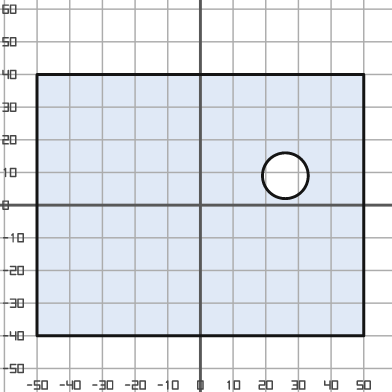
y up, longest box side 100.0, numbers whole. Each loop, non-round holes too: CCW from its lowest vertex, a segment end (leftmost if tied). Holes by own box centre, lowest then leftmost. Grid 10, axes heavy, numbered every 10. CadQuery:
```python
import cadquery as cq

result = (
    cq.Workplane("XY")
    .moveTo(-50.0, -40.0)
    .lineTo(50.0, -40.0)
    .lineTo(50.0, 40.0)
    .lineTo(-50.0, 40.0)
    .close()
    .moveTo(26.0, 9.0)
    .circle(7.0)
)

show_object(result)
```